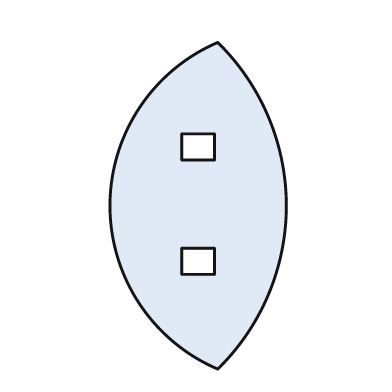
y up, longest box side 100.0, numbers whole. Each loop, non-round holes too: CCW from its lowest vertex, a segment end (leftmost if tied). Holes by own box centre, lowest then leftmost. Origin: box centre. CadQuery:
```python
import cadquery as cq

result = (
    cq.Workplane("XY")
    .moveTo(6.0, -50.0)
    .threePointArc((27.0, 0.0), (6.0, 50.0))
    .threePointArc((-27.0, 0.0), (6.0, -50.0))
    .close()
    .moveTo(-5.0, -21.0)
    .lineTo(5.0, -21.0)
    .lineTo(5.0, -13.0)
    .lineTo(-5.0, -13.0)
    .close()
    .moveTo(-5.0, 14.0)
    .lineTo(5.0, 14.0)
    .lineTo(5.0, 22.0)
    .lineTo(-5.0, 22.0)
    .close()
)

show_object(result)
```